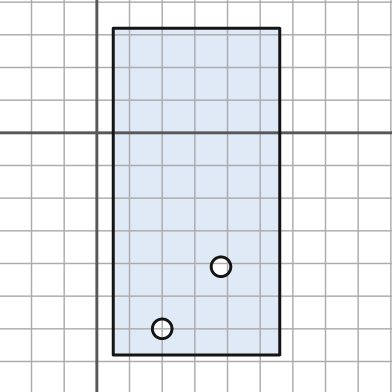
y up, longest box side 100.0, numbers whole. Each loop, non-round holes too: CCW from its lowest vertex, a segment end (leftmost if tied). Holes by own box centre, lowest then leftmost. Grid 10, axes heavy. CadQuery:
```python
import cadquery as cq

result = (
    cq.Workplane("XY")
    .moveTo(5.0, -68.0)
    .lineTo(56.0, -68.0)
    .lineTo(56.0, 32.0)
    .lineTo(5.0, 32.0)
    .close()
    .moveTo(20.0, -60.0)
    .circle(3.0)
    .moveTo(38.0, -41.0)
    .circle(3.0)
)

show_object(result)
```